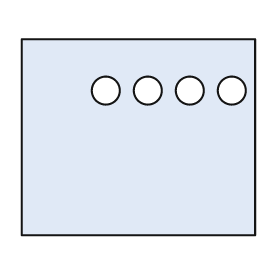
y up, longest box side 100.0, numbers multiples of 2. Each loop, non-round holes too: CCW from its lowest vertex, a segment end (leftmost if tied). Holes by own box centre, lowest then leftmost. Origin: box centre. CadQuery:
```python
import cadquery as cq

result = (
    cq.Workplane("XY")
    .moveTo(-50.0, -42.0)
    .lineTo(50.0, -42.0)
    .lineTo(50.0, 42.0)
    .lineTo(-50.0, 42.0)
    .close()
    .moveTo(-14.0, 20.0)
    .circle(6.0)
    .moveTo(4.0, 20.0)
    .circle(6.0)
    .moveTo(22.0, 20.0)
    .circle(6.0)
    .moveTo(40.0, 20.0)
    .circle(6.0)
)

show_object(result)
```